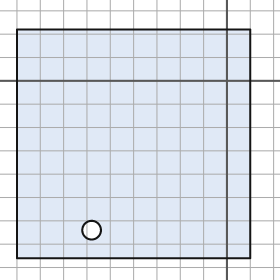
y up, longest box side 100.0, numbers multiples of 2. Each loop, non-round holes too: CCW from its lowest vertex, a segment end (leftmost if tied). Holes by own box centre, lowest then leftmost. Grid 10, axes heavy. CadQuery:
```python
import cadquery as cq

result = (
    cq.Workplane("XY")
    .moveTo(-90.0, -76.0)
    .lineTo(10.0, -76.0)
    .lineTo(10.0, 22.0)
    .lineTo(-90.0, 22.0)
    .close()
    .moveTo(-58.0, -64.0)
    .circle(4.0)
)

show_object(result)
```